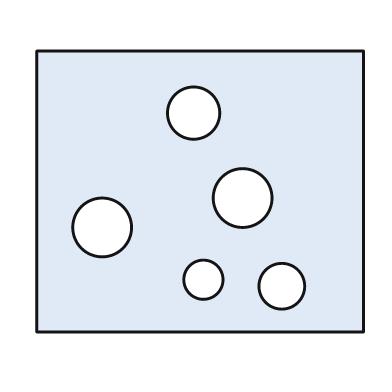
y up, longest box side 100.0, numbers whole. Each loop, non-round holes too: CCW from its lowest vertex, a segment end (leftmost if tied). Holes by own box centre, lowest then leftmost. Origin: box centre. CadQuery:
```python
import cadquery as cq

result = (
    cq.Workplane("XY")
    .moveTo(-50.0, -43.0)
    .lineTo(50.0, -43.0)
    .lineTo(50.0, 43.0)
    .lineTo(-50.0, 43.0)
    .close()
    .moveTo(25.0, -29.0)
    .circle(7.0)
    .moveTo(1.0, -27.0)
    .circle(6.0)
    .moveTo(-30.0, -11.0)
    .circle(9.0)
    .moveTo(13.0, -2.0)
    .circle(9.0)
    .moveTo(-2.0, 24.0)
    .circle(8.0)
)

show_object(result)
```